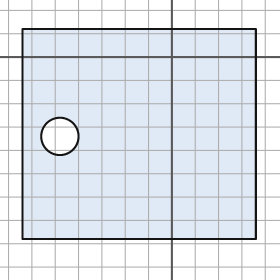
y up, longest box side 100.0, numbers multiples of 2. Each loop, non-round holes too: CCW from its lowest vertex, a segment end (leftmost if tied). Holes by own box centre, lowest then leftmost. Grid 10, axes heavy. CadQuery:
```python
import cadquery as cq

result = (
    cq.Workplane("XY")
    .moveTo(-64.0, -78.0)
    .lineTo(36.0, -78.0)
    .lineTo(36.0, 12.0)
    .lineTo(-64.0, 12.0)
    .close()
    .moveTo(-48.0, -34.0)
    .circle(8.0)
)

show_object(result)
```